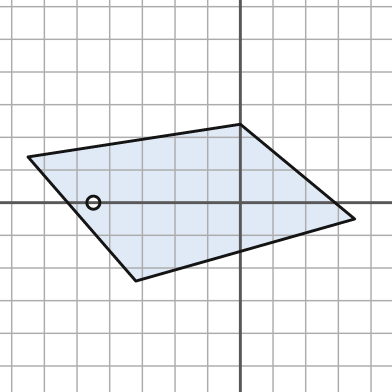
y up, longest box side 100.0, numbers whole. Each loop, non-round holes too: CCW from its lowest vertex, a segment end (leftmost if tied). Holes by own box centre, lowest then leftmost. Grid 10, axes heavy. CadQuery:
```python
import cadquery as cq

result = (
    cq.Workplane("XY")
    .moveTo(-32.0, -24.0)
    .lineTo(35.0, -5.0)
    .lineTo(0.0, 24.0)
    .lineTo(-65.0, 14.0)
    .close()
    .moveTo(-45.0, 0.0)
    .circle(2.0)
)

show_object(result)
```